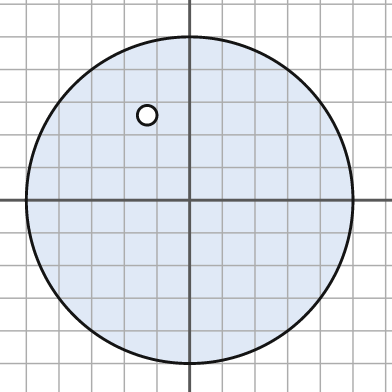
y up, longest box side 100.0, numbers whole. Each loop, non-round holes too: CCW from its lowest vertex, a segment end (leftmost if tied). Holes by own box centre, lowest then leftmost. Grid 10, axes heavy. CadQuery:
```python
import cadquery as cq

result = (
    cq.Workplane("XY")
    .moveTo(0.0, 0.0)
    .circle(50.0)
    .moveTo(-13.0, 26.0)
    .circle(3.0)
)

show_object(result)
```